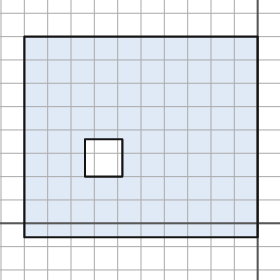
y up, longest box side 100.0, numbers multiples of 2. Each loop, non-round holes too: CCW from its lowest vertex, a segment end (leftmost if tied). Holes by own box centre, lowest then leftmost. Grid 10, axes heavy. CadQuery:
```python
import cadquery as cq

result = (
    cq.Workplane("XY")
    .moveTo(-100.0, -6.0)
    .lineTo(0.0, -6.0)
    .lineTo(0.0, 80.0)
    .lineTo(-100.0, 80.0)
    .close()
    .moveTo(-74.0, 20.0)
    .lineTo(-58.0, 20.0)
    .lineTo(-58.0, 36.0)
    .lineTo(-74.0, 36.0)
    .close()
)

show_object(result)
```